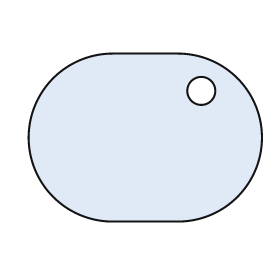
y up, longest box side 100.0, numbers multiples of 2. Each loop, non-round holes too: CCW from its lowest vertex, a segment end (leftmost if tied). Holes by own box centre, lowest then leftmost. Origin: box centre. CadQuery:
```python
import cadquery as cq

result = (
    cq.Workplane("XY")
    .moveTo(-14.0, -36.0)
    .lineTo(14.0, -36.0)
    .threePointArc((50.0, 0.0), (14.0, 36.0))
    .lineTo(-14.0, 36.0)
    .threePointArc((-50.0, 0.0), (-14.0, -36.0))
    .close()
    .moveTo(24.0, 20.0)
    .circle(6.0)
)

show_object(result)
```